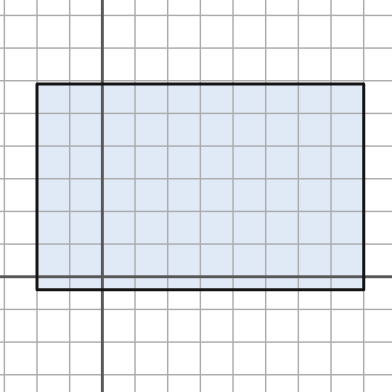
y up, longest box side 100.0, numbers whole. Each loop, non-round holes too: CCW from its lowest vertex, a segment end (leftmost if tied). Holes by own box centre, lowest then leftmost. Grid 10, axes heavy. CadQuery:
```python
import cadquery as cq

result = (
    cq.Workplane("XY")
    .moveTo(-20.0, -4.0)
    .lineTo(80.0, -4.0)
    .lineTo(80.0, 59.0)
    .lineTo(-20.0, 59.0)
    .close()
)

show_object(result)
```